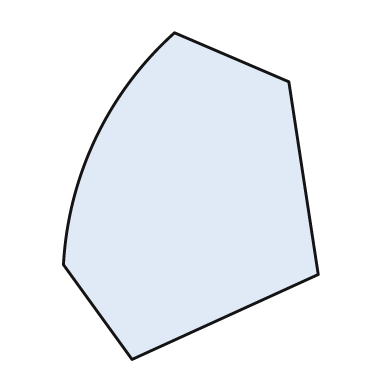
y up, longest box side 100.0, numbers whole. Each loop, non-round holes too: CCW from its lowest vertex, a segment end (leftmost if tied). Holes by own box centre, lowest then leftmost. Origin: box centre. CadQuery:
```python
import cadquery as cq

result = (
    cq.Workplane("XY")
    .moveTo(-18.0, -50.0)
    .lineTo(39.0, -24.0)
    .lineTo(30.0, 35.0)
    .lineTo(-5.0, 50.0)
    .threePointArc((-29.0, 18.0), (-39.0, -21.0))
    .close()
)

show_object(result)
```